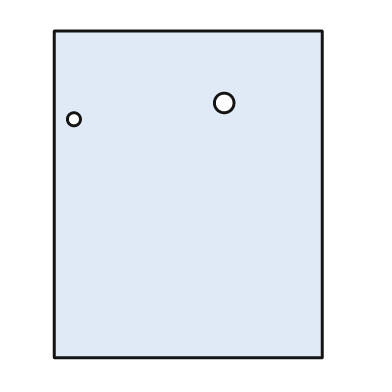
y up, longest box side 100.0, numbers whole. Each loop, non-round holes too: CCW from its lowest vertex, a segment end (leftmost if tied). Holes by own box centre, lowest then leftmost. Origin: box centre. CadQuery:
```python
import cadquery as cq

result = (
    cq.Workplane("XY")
    .moveTo(-41.0, -50.0)
    .lineTo(41.0, -50.0)
    .lineTo(41.0, 50.0)
    .lineTo(-41.0, 50.0)
    .close()
    .moveTo(-35.0, 23.0)
    .circle(2.0)
    .moveTo(11.0, 28.0)
    .circle(3.0)
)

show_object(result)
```